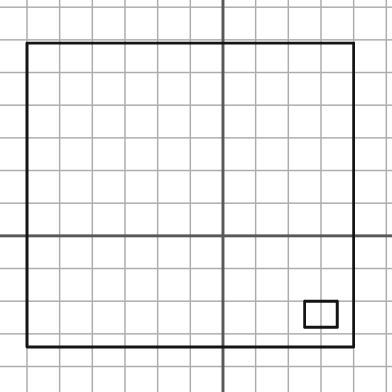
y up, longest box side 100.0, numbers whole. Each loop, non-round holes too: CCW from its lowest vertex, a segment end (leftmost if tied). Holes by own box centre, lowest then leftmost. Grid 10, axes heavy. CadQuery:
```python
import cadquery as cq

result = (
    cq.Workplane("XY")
    .moveTo(-60.0, -34.0)
    .lineTo(40.0, -34.0)
    .lineTo(40.0, 59.0)
    .lineTo(-60.0, 59.0)
    .close()
    .moveTo(25.0, -28.0)
    .lineTo(35.0, -28.0)
    .lineTo(35.0, -20.0)
    .lineTo(25.0, -20.0)
    .close()
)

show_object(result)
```